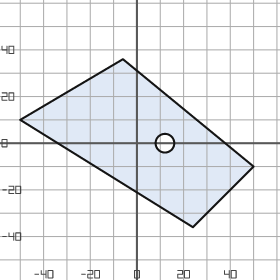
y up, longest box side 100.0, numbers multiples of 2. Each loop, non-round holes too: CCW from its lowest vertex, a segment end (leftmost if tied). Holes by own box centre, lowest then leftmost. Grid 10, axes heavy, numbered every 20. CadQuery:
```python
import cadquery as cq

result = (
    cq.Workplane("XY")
    .moveTo(24.0, -36.0)
    .lineTo(50.0, -10.0)
    .lineTo(-6.0, 36.0)
    .lineTo(-50.0, 10.0)
    .close()
    .moveTo(12.0, 0.0)
    .circle(4.0)
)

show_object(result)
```